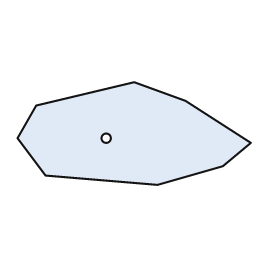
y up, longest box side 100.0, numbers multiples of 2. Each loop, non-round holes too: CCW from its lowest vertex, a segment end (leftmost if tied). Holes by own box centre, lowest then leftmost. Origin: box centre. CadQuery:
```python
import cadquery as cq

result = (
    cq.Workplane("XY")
    .moveTo(10.0, -22.0)
    .lineTo(38.0, -14.0)
    .lineTo(50.0, -4.0)
    .lineTo(22.0, 14.0)
    .lineTo(0.0, 22.0)
    .lineTo(-42.0, 12.0)
    .lineTo(-50.0, -2.0)
    .lineTo(-38.0, -18.0)
    .close()
    .moveTo(-12.0, -2.0)
    .circle(2.0)
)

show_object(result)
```